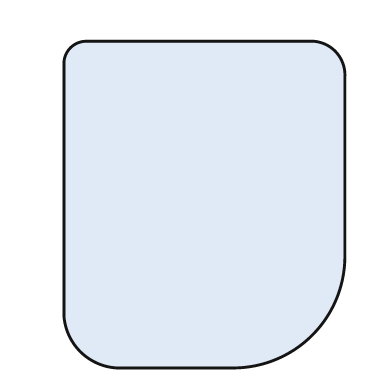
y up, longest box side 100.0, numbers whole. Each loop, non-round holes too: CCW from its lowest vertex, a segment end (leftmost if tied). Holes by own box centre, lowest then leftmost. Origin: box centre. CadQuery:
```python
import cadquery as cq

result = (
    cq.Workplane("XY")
    .moveTo(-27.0, -50.0)
    .lineTo(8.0, -50.0)
    .threePointArc((33.0, -40.0), (43.0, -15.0))
    .lineTo(43.0, 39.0)
    .threePointArc((40.0, 47.0), (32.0, 50.0))
    .lineTo(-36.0, 50.0)
    .threePointArc((-41.0, 48.0), (-43.0, 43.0))
    .lineTo(-43.0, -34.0)
    .threePointArc((-38.0, -45.0), (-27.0, -50.0))
    .close()
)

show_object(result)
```